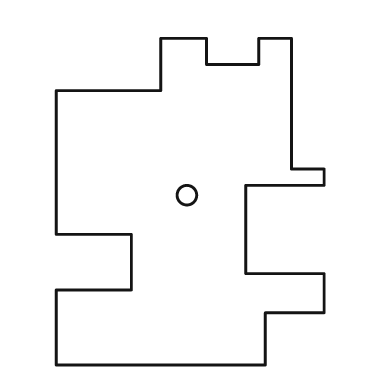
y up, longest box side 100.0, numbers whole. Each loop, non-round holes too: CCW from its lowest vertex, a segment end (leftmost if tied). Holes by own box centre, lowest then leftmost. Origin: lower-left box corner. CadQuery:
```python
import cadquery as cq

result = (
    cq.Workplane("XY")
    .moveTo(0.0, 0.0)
    .lineTo(64.0, 0.0)
    .lineTo(64.0, 16.0)
    .lineTo(82.0, 16.0)
    .lineTo(82.0, 28.0)
    .lineTo(58.0, 28.0)
    .lineTo(58.0, 55.0)
    .lineTo(82.0, 55.0)
    .lineTo(82.0, 60.0)
    .lineTo(72.0, 60.0)
    .lineTo(72.0, 100.0)
    .lineTo(62.0, 100.0)
    .lineTo(62.0, 92.0)
    .lineTo(46.0, 92.0)
    .lineTo(46.0, 100.0)
    .lineTo(32.0, 100.0)
    .lineTo(32.0, 84.0)
    .lineTo(0.0, 84.0)
    .lineTo(0.0, 40.0)
    .lineTo(23.0, 40.0)
    .lineTo(23.0, 23.0)
    .lineTo(0.0, 23.0)
    .close()
    .moveTo(40.0, 52.0)
    .circle(3.0)
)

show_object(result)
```